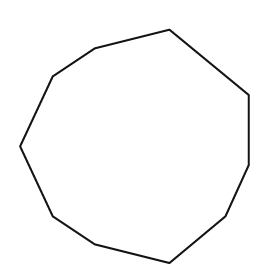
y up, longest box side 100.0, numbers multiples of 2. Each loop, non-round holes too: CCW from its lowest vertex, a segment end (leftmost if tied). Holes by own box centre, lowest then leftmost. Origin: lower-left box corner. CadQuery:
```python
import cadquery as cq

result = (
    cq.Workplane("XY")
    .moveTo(64.0, 0.0)
    .lineTo(88.0, 20.0)
    .lineTo(98.0, 42.0)
    .lineTo(98.0, 72.0)
    .lineTo(64.0, 100.0)
    .lineTo(32.0, 92.0)
    .lineTo(14.0, 80.0)
    .lineTo(0.0, 50.0)
    .lineTo(14.0, 20.0)
    .lineTo(32.0, 8.0)
    .close()
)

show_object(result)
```